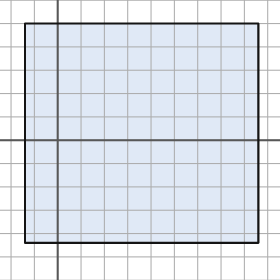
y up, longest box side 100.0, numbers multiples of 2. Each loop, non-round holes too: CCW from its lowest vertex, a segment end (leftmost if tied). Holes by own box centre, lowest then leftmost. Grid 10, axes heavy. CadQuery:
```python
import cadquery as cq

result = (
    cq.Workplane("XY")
    .moveTo(-14.0, -44.0)
    .lineTo(86.0, -44.0)
    .lineTo(86.0, 50.0)
    .lineTo(-14.0, 50.0)
    .close()
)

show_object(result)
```